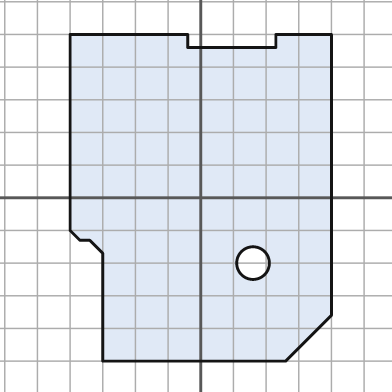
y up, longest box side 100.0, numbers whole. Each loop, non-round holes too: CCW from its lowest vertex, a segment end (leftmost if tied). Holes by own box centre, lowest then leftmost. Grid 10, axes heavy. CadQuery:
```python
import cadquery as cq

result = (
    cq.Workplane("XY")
    .moveTo(-30.0, -50.0)
    .lineTo(26.0, -50.0)
    .lineTo(40.0, -36.0)
    .lineTo(40.0, 50.0)
    .lineTo(23.0, 50.0)
    .lineTo(23.0, 46.0)
    .lineTo(-4.0, 46.0)
    .lineTo(-4.0, 50.0)
    .lineTo(-40.0, 50.0)
    .lineTo(-40.0, -10.0)
    .lineTo(-37.0, -13.0)
    .lineTo(-34.0, -13.0)
    .lineTo(-30.0, -17.0)
    .close()
    .moveTo(16.0, -20.0)
    .circle(5.0)
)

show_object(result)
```